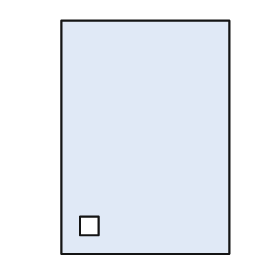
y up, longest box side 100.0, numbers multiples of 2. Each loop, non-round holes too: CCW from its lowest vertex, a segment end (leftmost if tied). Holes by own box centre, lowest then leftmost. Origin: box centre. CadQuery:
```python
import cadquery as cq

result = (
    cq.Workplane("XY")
    .moveTo(-36.0, -50.0)
    .lineTo(36.0, -50.0)
    .lineTo(36.0, 50.0)
    .lineTo(-36.0, 50.0)
    .close()
    .moveTo(-28.0, -42.0)
    .lineTo(-20.0, -42.0)
    .lineTo(-20.0, -34.0)
    .lineTo(-28.0, -34.0)
    .close()
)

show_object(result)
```